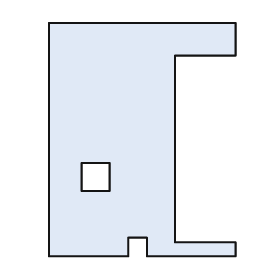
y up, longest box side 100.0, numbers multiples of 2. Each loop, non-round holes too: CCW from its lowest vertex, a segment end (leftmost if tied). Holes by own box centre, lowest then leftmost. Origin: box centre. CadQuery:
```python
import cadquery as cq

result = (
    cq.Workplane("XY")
    .moveTo(-40.0, -50.0)
    .lineTo(-6.0, -50.0)
    .lineTo(-6.0, -42.0)
    .lineTo(2.0, -42.0)
    .lineTo(2.0, -50.0)
    .lineTo(40.0, -50.0)
    .lineTo(40.0, -44.0)
    .lineTo(14.0, -44.0)
    .lineTo(14.0, 36.0)
    .lineTo(40.0, 36.0)
    .lineTo(40.0, 50.0)
    .lineTo(-40.0, 50.0)
    .close()
    .moveTo(-26.0, -22.0)
    .lineTo(-14.0, -22.0)
    .lineTo(-14.0, -10.0)
    .lineTo(-26.0, -10.0)
    .close()
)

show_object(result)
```